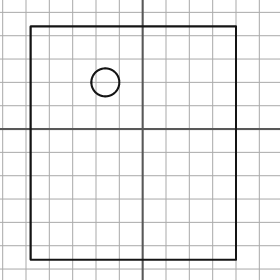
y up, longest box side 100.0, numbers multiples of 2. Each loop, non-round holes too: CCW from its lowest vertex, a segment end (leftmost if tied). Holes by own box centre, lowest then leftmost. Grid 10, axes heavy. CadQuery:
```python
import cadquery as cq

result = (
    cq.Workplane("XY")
    .moveTo(-48.0, -56.0)
    .lineTo(40.0, -56.0)
    .lineTo(40.0, 44.0)
    .lineTo(-48.0, 44.0)
    .close()
    .moveTo(-16.0, 20.0)
    .circle(6.0)
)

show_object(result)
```